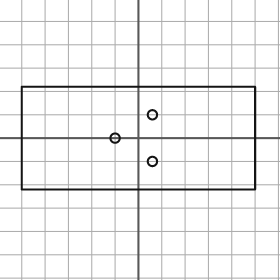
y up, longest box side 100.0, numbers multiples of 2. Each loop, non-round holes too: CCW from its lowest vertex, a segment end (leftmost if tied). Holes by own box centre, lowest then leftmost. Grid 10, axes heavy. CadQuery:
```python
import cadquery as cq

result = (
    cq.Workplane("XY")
    .moveTo(-50.0, -22.0)
    .lineTo(50.0, -22.0)
    .lineTo(50.0, 22.0)
    .lineTo(-50.0, 22.0)
    .close()
    .moveTo(6.0, -10.0)
    .circle(2.0)
    .moveTo(-10.0, 0.0)
    .circle(2.0)
    .moveTo(6.0, 10.0)
    .circle(2.0)
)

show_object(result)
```